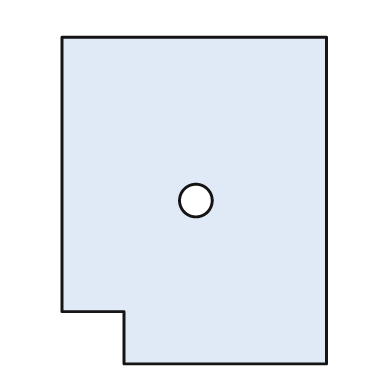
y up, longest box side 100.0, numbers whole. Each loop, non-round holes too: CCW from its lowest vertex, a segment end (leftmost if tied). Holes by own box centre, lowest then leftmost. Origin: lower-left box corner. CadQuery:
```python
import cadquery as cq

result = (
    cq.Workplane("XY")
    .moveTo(19.0, 0.0)
    .lineTo(81.0, 0.0)
    .lineTo(81.0, 100.0)
    .lineTo(0.0, 100.0)
    .lineTo(0.0, 16.0)
    .lineTo(19.0, 16.0)
    .close()
    .moveTo(41.0, 50.0)
    .circle(5.0)
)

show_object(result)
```